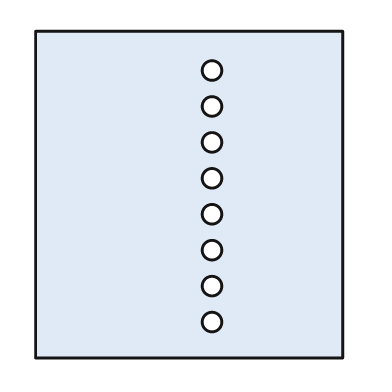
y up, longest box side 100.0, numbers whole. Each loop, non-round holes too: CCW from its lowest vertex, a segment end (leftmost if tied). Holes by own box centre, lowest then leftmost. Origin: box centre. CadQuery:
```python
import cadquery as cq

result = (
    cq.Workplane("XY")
    .moveTo(-47.0, -50.0)
    .lineTo(47.0, -50.0)
    .lineTo(47.0, 50.0)
    .lineTo(-47.0, 50.0)
    .close()
    .moveTo(7.0, -39.0)
    .circle(3.0)
    .moveTo(7.0, -28.0)
    .circle(3.0)
    .moveTo(7.0, -17.0)
    .circle(3.0)
    .moveTo(7.0, -6.0)
    .circle(3.0)
    .moveTo(7.0, 5.0)
    .circle(3.0)
    .moveTo(7.0, 16.0)
    .circle(3.0)
    .moveTo(7.0, 27.0)
    .circle(3.0)
    .moveTo(7.0, 38.0)
    .circle(3.0)
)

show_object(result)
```